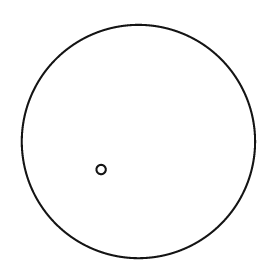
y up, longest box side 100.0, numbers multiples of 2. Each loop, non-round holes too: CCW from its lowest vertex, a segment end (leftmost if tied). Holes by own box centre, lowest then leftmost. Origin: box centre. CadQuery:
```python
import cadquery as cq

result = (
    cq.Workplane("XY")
    .moveTo(0.0, 0.0)
    .circle(50.0)
    .moveTo(-16.0, -12.0)
    .circle(2.0)
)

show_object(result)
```